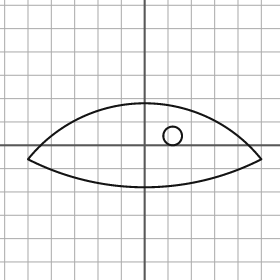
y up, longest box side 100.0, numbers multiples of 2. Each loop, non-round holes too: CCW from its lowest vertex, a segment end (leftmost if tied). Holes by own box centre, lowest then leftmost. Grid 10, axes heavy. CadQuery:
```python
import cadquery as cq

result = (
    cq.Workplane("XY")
    .moveTo(-50.0, -6.0)
    .threePointArc((0.0, -18.0), (50.0, -6.0))
    .threePointArc((0.0, 18.0), (-50.0, -6.0))
    .close()
    .moveTo(12.0, 4.0)
    .circle(4.0)
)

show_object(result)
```